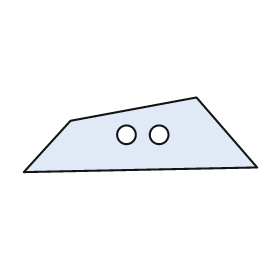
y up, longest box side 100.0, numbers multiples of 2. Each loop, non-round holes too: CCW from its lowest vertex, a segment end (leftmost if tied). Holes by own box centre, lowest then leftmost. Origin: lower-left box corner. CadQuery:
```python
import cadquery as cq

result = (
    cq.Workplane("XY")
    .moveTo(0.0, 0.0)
    .lineTo(100.0, 2.0)
    .lineTo(74.0, 32.0)
    .lineTo(20.0, 22.0)
    .close()
    .moveTo(44.0, 16.0)
    .circle(4.0)
    .moveTo(58.0, 16.0)
    .circle(4.0)
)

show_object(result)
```